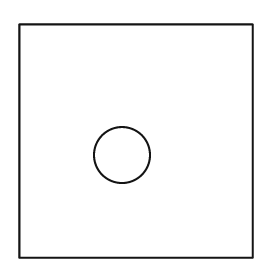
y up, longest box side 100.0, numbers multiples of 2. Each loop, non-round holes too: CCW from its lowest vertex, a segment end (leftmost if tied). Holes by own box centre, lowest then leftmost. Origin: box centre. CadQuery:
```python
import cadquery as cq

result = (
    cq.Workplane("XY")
    .moveTo(-50.0, -50.0)
    .lineTo(50.0, -50.0)
    .lineTo(50.0, 50.0)
    .lineTo(-50.0, 50.0)
    .close()
    .moveTo(-6.0, -6.0)
    .circle(12.0)
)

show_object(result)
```